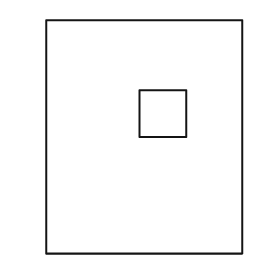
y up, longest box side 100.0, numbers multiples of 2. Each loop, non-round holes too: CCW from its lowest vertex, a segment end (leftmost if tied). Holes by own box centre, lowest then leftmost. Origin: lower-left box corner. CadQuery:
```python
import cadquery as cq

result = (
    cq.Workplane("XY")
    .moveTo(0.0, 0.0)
    .lineTo(84.0, 0.0)
    .lineTo(84.0, 100.0)
    .lineTo(0.0, 100.0)
    .close()
    .moveTo(40.0, 50.0)
    .lineTo(60.0, 50.0)
    .lineTo(60.0, 70.0)
    .lineTo(40.0, 70.0)
    .close()
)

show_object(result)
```